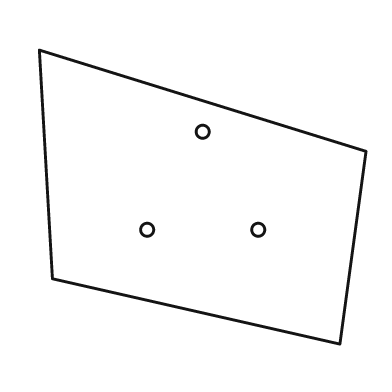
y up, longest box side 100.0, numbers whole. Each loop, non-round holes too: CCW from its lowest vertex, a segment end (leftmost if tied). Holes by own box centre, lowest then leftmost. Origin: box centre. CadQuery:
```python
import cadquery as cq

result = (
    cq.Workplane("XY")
    .moveTo(42.0, -45.0)
    .lineTo(50.0, 14.0)
    .lineTo(-50.0, 45.0)
    .lineTo(-46.0, -25.0)
    .close()
    .moveTo(-17.0, -10.0)
    .circle(2.0)
    .moveTo(17.0, -10.0)
    .circle(2.0)
    .moveTo(0.0, 20.0)
    .circle(2.0)
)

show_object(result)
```